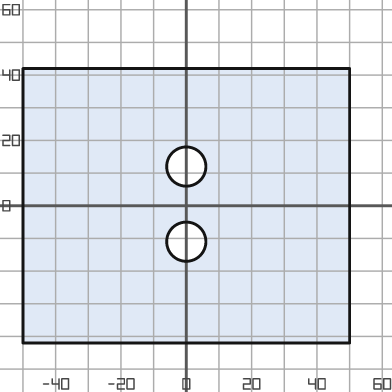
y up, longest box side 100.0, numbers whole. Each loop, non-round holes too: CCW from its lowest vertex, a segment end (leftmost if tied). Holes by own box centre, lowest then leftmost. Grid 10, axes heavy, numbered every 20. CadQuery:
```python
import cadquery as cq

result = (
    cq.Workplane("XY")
    .moveTo(-50.0, -42.0)
    .lineTo(50.0, -42.0)
    .lineTo(50.0, 42.0)
    .lineTo(-50.0, 42.0)
    .close()
    .moveTo(0.0, -11.0)
    .circle(6.0)
    .moveTo(0.0, 12.0)
    .circle(6.0)
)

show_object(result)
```